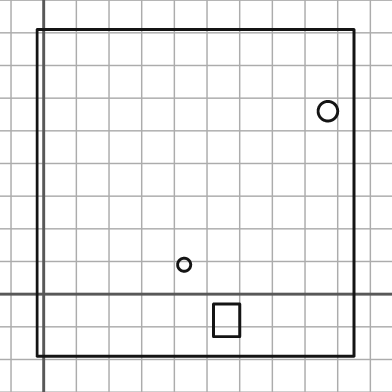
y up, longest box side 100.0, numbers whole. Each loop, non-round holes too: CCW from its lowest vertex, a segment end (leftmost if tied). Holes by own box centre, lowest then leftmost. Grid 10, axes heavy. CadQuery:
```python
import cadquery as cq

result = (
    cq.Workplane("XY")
    .moveTo(-2.0, -19.0)
    .lineTo(95.0, -19.0)
    .lineTo(95.0, 81.0)
    .lineTo(-2.0, 81.0)
    .close()
    .moveTo(52.0, -13.0)
    .lineTo(60.0, -13.0)
    .lineTo(60.0, -3.0)
    .lineTo(52.0, -3.0)
    .close()
    .moveTo(43.0, 9.0)
    .circle(2.0)
    .moveTo(87.0, 56.0)
    .circle(3.0)
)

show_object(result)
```